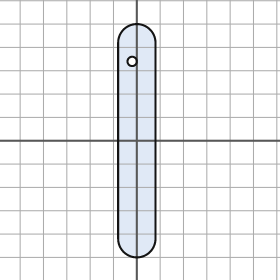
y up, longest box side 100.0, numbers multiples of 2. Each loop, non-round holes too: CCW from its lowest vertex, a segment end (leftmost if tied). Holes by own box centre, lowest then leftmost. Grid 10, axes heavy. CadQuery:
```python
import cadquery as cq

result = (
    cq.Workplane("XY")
    .moveTo(-8.0, -42.0)
    .threePointArc((0.0, -50.0), (8.0, -42.0))
    .lineTo(8.0, 42.0)
    .threePointArc((0.0, 50.0), (-8.0, 42.0))
    .close()
    .moveTo(-2.0, 34.0)
    .circle(2.0)
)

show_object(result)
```